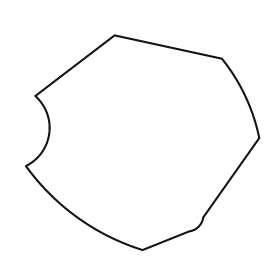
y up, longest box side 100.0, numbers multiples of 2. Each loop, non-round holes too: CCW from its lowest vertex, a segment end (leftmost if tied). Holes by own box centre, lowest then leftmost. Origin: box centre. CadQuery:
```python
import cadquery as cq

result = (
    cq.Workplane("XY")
    .moveTo(0.0, -46.0)
    .lineTo(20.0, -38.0)
    .threePointArc((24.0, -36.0), (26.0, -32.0))
    .lineTo(50.0, 2.0)
    .threePointArc((44.0, 20.0), (34.0, 36.0))
    .lineTo(-12.0, 46.0)
    .lineTo(-46.0, 20.0)
    .threePointArc((-40.0, 4.0), (-50.0, -10.0))
    .threePointArc((-28.0, -32.0), (0.0, -46.0))
    .close()
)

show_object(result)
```